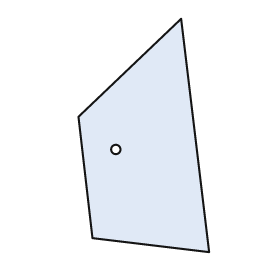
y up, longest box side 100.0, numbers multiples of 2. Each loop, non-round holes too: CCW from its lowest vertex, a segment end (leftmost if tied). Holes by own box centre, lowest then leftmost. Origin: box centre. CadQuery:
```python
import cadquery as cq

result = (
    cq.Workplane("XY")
    .moveTo(28.0, -50.0)
    .lineTo(16.0, 50.0)
    .lineTo(-28.0, 8.0)
    .lineTo(-22.0, -44.0)
    .close()
    .moveTo(-12.0, -6.0)
    .circle(2.0)
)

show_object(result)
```